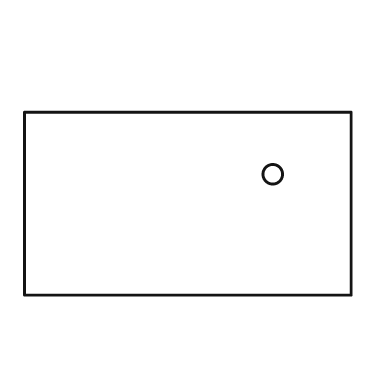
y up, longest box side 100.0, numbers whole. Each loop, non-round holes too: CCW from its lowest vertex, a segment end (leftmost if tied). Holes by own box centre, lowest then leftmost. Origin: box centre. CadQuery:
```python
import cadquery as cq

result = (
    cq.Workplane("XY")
    .moveTo(-50.0, -28.0)
    .lineTo(50.0, -28.0)
    .lineTo(50.0, 28.0)
    .lineTo(-50.0, 28.0)
    .close()
    .moveTo(26.0, 9.0)
    .circle(3.0)
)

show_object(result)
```